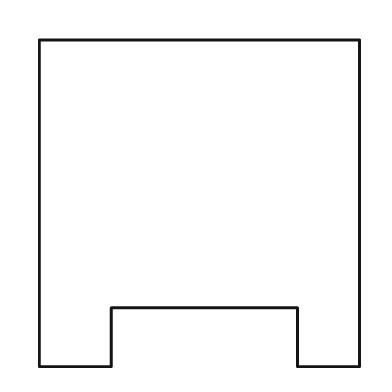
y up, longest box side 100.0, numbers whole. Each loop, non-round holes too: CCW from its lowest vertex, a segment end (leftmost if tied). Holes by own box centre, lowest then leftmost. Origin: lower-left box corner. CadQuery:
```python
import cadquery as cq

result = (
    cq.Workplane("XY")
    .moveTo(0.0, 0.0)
    .lineTo(22.0, 0.0)
    .lineTo(22.0, 18.0)
    .lineTo(79.0, 18.0)
    .lineTo(79.0, 0.0)
    .lineTo(98.0, 0.0)
    .lineTo(98.0, 100.0)
    .lineTo(0.0, 100.0)
    .close()
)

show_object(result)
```